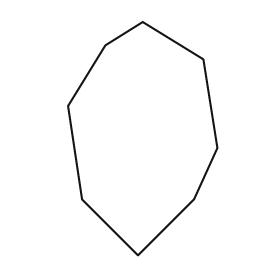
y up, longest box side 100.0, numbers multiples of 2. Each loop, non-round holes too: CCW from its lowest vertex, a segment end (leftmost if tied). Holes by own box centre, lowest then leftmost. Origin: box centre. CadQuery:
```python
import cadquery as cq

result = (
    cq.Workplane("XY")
    .moveTo(-2.0, -50.0)
    .lineTo(22.0, -26.0)
    .lineTo(32.0, -4.0)
    .lineTo(26.0, 34.0)
    .lineTo(0.0, 50.0)
    .lineTo(-16.0, 40.0)
    .lineTo(-32.0, 14.0)
    .lineTo(-26.0, -26.0)
    .close()
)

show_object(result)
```